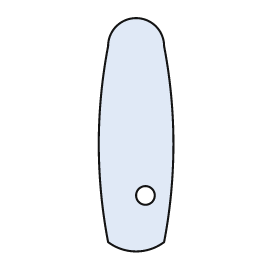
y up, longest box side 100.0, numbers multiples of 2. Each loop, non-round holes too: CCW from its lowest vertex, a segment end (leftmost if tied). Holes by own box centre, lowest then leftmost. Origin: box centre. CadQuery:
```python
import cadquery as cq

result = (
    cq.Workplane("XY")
    .moveTo(-12.0, -46.0)
    .threePointArc((0.0, -50.0), (12.0, -46.0))
    .threePointArc((16.0, -4.0), (12.0, 38.0))
    .threePointArc((0.0, 50.0), (-12.0, 38.0))
    .threePointArc((-16.0, -4.0), (-12.0, -46.0))
    .close()
    .moveTo(4.0, -26.0)
    .circle(4.0)
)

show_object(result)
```